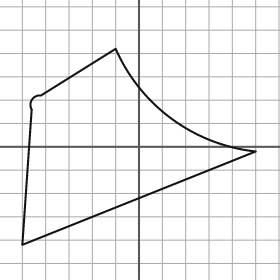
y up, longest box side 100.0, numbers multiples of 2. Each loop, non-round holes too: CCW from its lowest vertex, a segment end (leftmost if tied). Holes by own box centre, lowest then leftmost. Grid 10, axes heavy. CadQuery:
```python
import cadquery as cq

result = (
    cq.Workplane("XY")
    .moveTo(-50.0, -42.0)
    .lineTo(50.0, -2.0)
    .threePointArc((14.0, 12.0), (-10.0, 42.0))
    .lineTo(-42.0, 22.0)
    .threePointArc((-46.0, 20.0), (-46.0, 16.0))
    .close()
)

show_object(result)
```